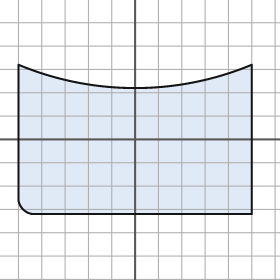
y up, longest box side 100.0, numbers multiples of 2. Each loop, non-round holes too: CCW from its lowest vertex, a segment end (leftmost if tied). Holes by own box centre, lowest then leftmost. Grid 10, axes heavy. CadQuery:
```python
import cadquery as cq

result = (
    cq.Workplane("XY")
    .moveTo(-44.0, -32.0)
    .lineTo(50.0, -32.0)
    .lineTo(50.0, 32.0)
    .threePointArc((0.0, 22.0), (-50.0, 32.0))
    .lineTo(-50.0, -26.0)
    .threePointArc((-48.0, -30.0), (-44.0, -32.0))
    .close()
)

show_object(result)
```